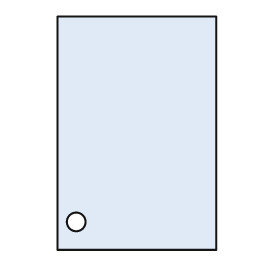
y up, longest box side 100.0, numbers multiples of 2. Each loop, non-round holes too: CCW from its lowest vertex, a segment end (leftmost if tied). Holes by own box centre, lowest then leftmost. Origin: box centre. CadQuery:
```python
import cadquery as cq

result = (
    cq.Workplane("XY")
    .moveTo(-34.0, -50.0)
    .lineTo(34.0, -50.0)
    .lineTo(34.0, 50.0)
    .lineTo(-34.0, 50.0)
    .close()
    .moveTo(-26.0, -38.0)
    .circle(4.0)
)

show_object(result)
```